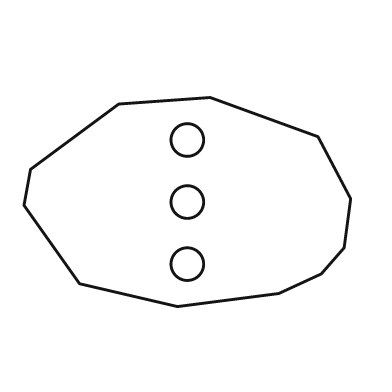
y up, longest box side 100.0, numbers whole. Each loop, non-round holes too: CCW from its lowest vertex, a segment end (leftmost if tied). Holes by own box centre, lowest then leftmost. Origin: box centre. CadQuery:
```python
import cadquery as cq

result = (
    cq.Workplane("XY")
    .moveTo(-3.0, -32.0)
    .lineTo(28.0, -28.0)
    .lineTo(41.0, -22.0)
    .lineTo(48.0, -14.0)
    .lineTo(50.0, 1.0)
    .lineTo(40.0, 20.0)
    .lineTo(7.0, 32.0)
    .lineTo(-21.0, 30.0)
    .lineTo(-48.0, 10.0)
    .lineTo(-50.0, -1.0)
    .lineTo(-33.0, -25.0)
    .close()
    .moveTo(0.0, -19.0)
    .circle(5.0)
    .moveTo(0.0, 0.0)
    .circle(5.0)
    .moveTo(0.0, 19.0)
    .circle(5.0)
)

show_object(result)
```